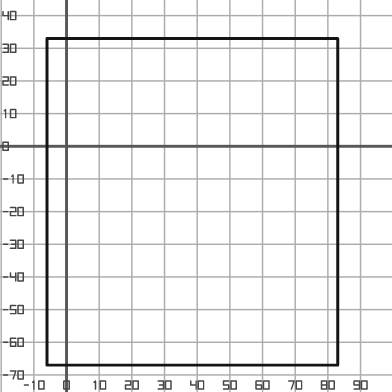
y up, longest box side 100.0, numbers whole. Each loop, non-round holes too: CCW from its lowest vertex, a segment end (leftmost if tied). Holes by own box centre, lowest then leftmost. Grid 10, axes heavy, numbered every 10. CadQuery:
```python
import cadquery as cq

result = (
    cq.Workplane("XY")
    .moveTo(-6.0, -67.0)
    .lineTo(83.0, -67.0)
    .lineTo(83.0, 33.0)
    .lineTo(-6.0, 33.0)
    .close()
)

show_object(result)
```